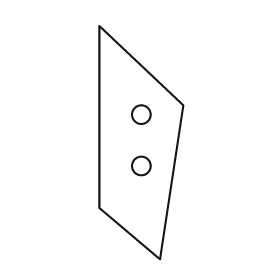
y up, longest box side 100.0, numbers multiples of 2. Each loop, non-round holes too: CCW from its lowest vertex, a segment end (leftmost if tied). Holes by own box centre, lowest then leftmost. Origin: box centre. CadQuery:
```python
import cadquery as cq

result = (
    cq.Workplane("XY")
    .moveTo(8.0, -50.0)
    .lineTo(18.0, 16.0)
    .lineTo(-18.0, 50.0)
    .lineTo(-18.0, -28.0)
    .close()
    .moveTo(0.0, -10.0)
    .circle(4.0)
    .moveTo(0.0, 12.0)
    .circle(4.0)
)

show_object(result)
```